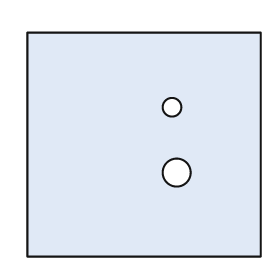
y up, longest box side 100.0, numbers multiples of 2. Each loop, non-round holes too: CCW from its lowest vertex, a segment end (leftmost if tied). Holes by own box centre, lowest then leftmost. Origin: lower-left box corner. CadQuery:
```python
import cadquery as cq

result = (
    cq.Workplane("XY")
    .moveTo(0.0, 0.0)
    .lineTo(100.0, 0.0)
    .lineTo(100.0, 96.0)
    .lineTo(0.0, 96.0)
    .close()
    .moveTo(64.0, 36.0)
    .circle(6.0)
    .moveTo(62.0, 64.0)
    .circle(4.0)
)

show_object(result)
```